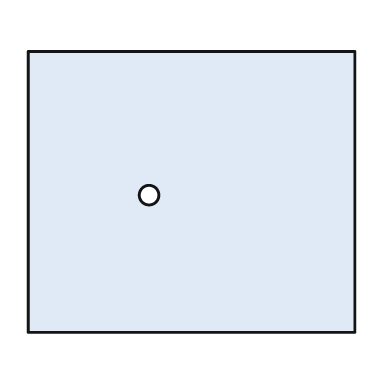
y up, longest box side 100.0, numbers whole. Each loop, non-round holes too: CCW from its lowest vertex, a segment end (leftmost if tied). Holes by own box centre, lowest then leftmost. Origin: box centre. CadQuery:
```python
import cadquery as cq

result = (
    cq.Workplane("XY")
    .moveTo(-50.0, -43.0)
    .lineTo(50.0, -43.0)
    .lineTo(50.0, 43.0)
    .lineTo(-50.0, 43.0)
    .close()
    .moveTo(-13.0, -1.0)
    .circle(3.0)
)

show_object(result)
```